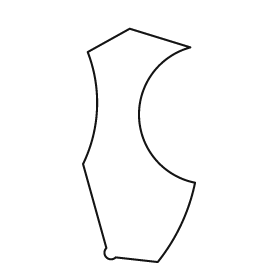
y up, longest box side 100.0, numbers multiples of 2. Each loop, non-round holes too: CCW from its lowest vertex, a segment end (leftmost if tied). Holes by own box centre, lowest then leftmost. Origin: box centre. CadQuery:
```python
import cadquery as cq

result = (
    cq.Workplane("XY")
    .moveTo(8.0, -50.0)
    .threePointArc((18.0, -34.0), (24.0, -16.0))
    .threePointArc((0.0, 12.0), (22.0, 42.0))
    .lineTo(-4.0, 50.0)
    .lineTo(-22.0, 40.0)
    .threePointArc((-18.0, 16.0), (-24.0, -8.0))
    .lineTo(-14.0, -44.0)
    .threePointArc((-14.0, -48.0), (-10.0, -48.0))
    .close()
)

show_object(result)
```